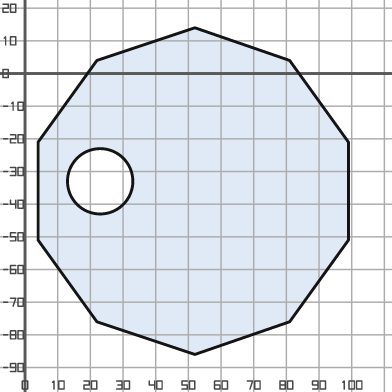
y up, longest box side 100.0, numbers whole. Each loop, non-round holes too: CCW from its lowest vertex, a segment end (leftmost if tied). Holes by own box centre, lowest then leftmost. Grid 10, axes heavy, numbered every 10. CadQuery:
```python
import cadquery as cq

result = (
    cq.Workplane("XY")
    .moveTo(52.0, -86.0)
    .lineTo(81.0, -76.0)
    .lineTo(99.0, -51.0)
    .lineTo(99.0, -21.0)
    .lineTo(81.0, 4.0)
    .lineTo(52.0, 14.0)
    .lineTo(22.0, 4.0)
    .lineTo(4.0, -21.0)
    .lineTo(4.0, -51.0)
    .lineTo(22.0, -76.0)
    .close()
    .moveTo(23.0, -33.0)
    .circle(10.0)
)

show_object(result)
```